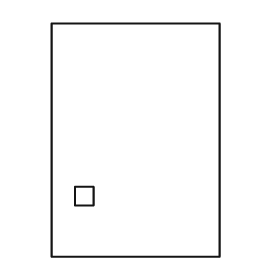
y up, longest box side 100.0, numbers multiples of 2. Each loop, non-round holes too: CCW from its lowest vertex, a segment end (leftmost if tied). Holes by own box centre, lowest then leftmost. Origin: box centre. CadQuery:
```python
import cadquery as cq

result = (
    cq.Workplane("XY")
    .moveTo(-36.0, -50.0)
    .lineTo(36.0, -50.0)
    .lineTo(36.0, 50.0)
    .lineTo(-36.0, 50.0)
    .close()
    .moveTo(-26.0, -28.0)
    .lineTo(-18.0, -28.0)
    .lineTo(-18.0, -20.0)
    .lineTo(-26.0, -20.0)
    .close()
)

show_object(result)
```